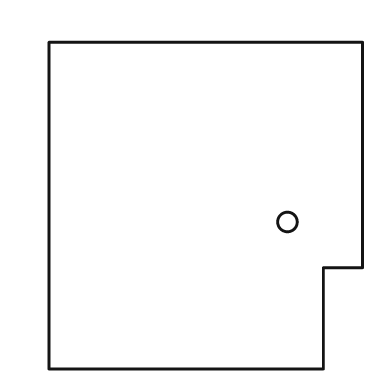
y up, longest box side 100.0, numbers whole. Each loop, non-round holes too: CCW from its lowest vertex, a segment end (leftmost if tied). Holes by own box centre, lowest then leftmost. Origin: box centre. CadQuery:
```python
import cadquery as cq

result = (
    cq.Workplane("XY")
    .moveTo(-48.0, -50.0)
    .lineTo(36.0, -50.0)
    .lineTo(36.0, -19.0)
    .lineTo(48.0, -19.0)
    .lineTo(48.0, 50.0)
    .lineTo(-48.0, 50.0)
    .close()
    .moveTo(25.0, -5.0)
    .circle(3.0)
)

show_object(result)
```